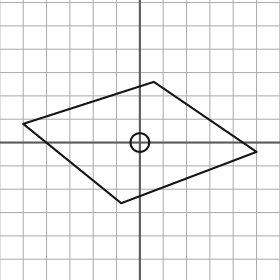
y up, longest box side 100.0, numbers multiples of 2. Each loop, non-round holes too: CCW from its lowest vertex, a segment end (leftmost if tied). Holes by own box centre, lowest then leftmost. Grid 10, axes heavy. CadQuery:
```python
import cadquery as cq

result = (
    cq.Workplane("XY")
    .moveTo(-8.0, -26.0)
    .lineTo(50.0, -4.0)
    .lineTo(6.0, 26.0)
    .lineTo(-50.0, 8.0)
    .close()
    .moveTo(0.0, 0.0)
    .circle(4.0)
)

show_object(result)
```